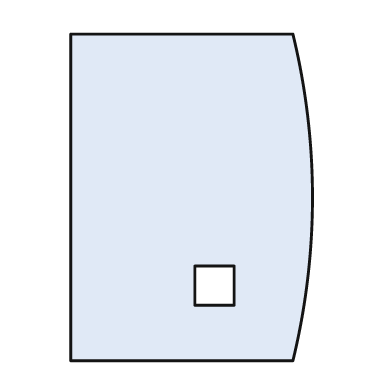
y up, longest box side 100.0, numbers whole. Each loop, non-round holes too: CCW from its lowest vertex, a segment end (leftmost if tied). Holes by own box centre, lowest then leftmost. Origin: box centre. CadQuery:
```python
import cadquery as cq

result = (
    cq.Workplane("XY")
    .moveTo(-37.0, -50.0)
    .lineTo(31.0, -50.0)
    .threePointArc((37.0, 0.0), (31.0, 50.0))
    .lineTo(-37.0, 50.0)
    .close()
    .moveTo(1.0, -33.0)
    .lineTo(13.0, -33.0)
    .lineTo(13.0, -21.0)
    .lineTo(1.0, -21.0)
    .close()
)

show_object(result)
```